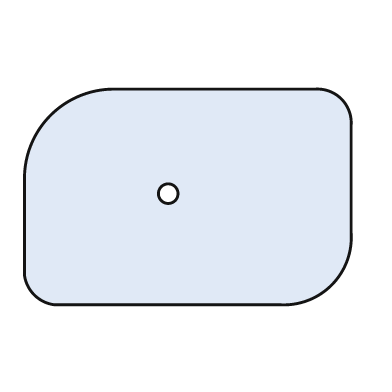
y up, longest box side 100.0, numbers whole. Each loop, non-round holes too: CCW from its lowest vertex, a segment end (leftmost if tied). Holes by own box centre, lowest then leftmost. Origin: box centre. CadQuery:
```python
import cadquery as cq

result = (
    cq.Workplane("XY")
    .moveTo(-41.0, -33.0)
    .lineTo(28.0, -33.0)
    .threePointArc((44.0, -27.0), (50.0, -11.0))
    .lineTo(50.0, 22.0)
    .threePointArc((47.0, 30.0), (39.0, 33.0))
    .lineTo(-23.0, 33.0)
    .threePointArc((-42.0, 25.0), (-50.0, 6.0))
    .lineTo(-50.0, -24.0)
    .threePointArc((-47.0, -30.0), (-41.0, -33.0))
    .close()
    .moveTo(-6.0, 1.0)
    .circle(3.0)
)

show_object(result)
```